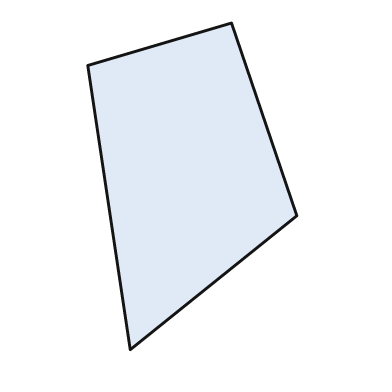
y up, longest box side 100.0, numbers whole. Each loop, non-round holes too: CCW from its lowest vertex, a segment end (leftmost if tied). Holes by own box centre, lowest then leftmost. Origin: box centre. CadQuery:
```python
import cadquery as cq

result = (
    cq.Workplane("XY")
    .moveTo(-19.0, -50.0)
    .lineTo(32.0, -9.0)
    .lineTo(12.0, 50.0)
    .lineTo(-32.0, 37.0)
    .close()
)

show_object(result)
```